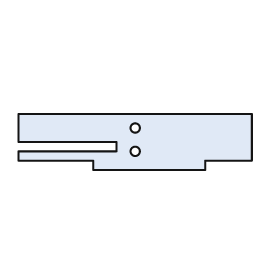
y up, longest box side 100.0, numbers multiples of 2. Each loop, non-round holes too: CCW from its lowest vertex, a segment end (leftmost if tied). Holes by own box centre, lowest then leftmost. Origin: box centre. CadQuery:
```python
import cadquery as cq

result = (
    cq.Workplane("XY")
    .moveTo(-18.0, -12.0)
    .lineTo(30.0, -12.0)
    .lineTo(30.0, -8.0)
    .lineTo(50.0, -8.0)
    .lineTo(50.0, 12.0)
    .lineTo(-50.0, 12.0)
    .lineTo(-50.0, 0.0)
    .lineTo(-8.0, 0.0)
    .lineTo(-8.0, -4.0)
    .lineTo(-50.0, -4.0)
    .lineTo(-50.0, -8.0)
    .lineTo(-18.0, -8.0)
    .close()
    .moveTo(0.0, -4.0)
    .circle(2.0)
    .moveTo(0.0, 6.0)
    .circle(2.0)
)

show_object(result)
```